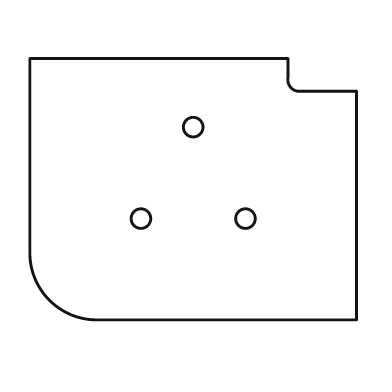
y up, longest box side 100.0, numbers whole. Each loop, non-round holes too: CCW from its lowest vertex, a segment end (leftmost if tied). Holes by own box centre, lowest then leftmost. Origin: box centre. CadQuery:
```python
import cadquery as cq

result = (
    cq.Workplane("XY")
    .moveTo(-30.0, -40.0)
    .lineTo(50.0, -40.0)
    .lineTo(50.0, 30.0)
    .lineTo(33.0, 30.0)
    .threePointArc((30.0, 31.0), (29.0, 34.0))
    .lineTo(29.0, 40.0)
    .lineTo(-50.0, 40.0)
    .lineTo(-50.0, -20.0)
    .threePointArc((-44.0, -34.0), (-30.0, -40.0))
    .close()
    .moveTo(-16.0, -9.0)
    .circle(3.0)
    .moveTo(16.0, -9.0)
    .circle(3.0)
    .moveTo(0.0, 19.0)
    .circle(3.0)
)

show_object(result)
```